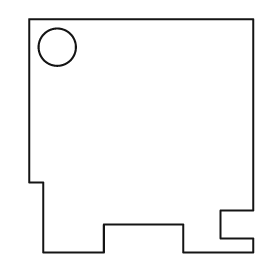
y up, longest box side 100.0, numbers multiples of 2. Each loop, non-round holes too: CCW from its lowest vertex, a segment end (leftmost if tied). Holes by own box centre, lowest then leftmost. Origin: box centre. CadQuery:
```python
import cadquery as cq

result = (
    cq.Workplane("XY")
    .moveTo(-42.0, -50.0)
    .lineTo(-16.0, -50.0)
    .lineTo(-16.0, -38.0)
    .lineTo(18.0, -38.0)
    .lineTo(18.0, -50.0)
    .lineTo(48.0, -50.0)
    .lineTo(48.0, -44.0)
    .lineTo(34.0, -44.0)
    .lineTo(34.0, -32.0)
    .lineTo(48.0, -32.0)
    .lineTo(48.0, 50.0)
    .lineTo(-48.0, 50.0)
    .lineTo(-48.0, -20.0)
    .lineTo(-42.0, -20.0)
    .close()
    .moveTo(-36.0, 38.0)
    .circle(8.0)
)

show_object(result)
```